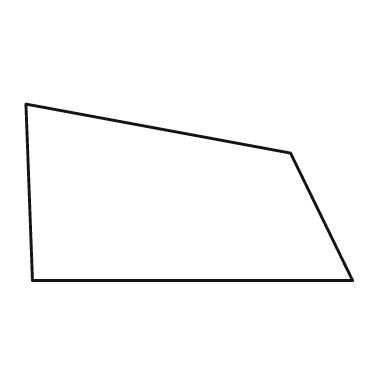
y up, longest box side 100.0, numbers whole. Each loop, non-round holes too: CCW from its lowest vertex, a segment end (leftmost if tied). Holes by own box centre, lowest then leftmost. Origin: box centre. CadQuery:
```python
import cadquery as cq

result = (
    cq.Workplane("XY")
    .moveTo(-48.0, -27.0)
    .lineTo(50.0, -27.0)
    .lineTo(31.0, 12.0)
    .lineTo(-50.0, 27.0)
    .close()
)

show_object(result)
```